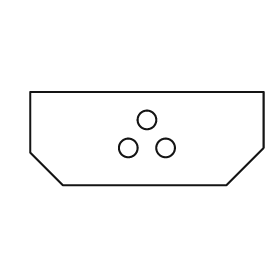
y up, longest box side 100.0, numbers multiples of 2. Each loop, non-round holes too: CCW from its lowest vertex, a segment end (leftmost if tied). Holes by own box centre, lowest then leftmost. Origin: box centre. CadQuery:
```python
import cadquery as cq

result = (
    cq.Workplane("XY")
    .moveTo(-36.0, -20.0)
    .lineTo(34.0, -20.0)
    .lineTo(50.0, -4.0)
    .lineTo(50.0, 20.0)
    .lineTo(-50.0, 20.0)
    .lineTo(-50.0, -6.0)
    .close()
    .moveTo(-8.0, -4.0)
    .circle(4.0)
    .moveTo(8.0, -4.0)
    .circle(4.0)
    .moveTo(0.0, 8.0)
    .circle(4.0)
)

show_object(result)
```